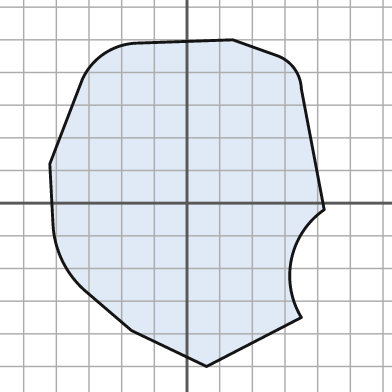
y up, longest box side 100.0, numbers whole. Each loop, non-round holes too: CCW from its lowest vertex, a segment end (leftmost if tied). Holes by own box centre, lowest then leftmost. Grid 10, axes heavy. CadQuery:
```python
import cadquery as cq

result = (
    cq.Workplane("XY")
    .moveTo(6.0, -50.0)
    .lineTo(35.0, -35.0)
    .threePointArc((32.0, -17.0), (42.0, -2.0))
    .lineTo(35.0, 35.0)
    .threePointArc((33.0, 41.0), (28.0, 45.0))
    .lineTo(14.0, 50.0)
    .lineTo(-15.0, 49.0)
    .threePointArc((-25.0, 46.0), (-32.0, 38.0))
    .lineTo(-42.0, 12.0)
    .lineTo(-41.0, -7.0)
    .threePointArc((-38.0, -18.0), (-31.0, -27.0))
    .lineTo(-17.0, -39.0)
    .close()
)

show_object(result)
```